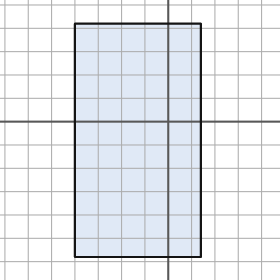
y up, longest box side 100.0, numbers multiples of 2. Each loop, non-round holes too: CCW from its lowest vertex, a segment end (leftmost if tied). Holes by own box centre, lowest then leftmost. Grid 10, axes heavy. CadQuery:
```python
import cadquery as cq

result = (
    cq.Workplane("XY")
    .moveTo(-40.0, -58.0)
    .lineTo(14.0, -58.0)
    .lineTo(14.0, 42.0)
    .lineTo(-40.0, 42.0)
    .close()
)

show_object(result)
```